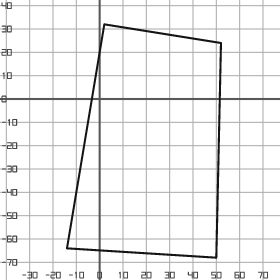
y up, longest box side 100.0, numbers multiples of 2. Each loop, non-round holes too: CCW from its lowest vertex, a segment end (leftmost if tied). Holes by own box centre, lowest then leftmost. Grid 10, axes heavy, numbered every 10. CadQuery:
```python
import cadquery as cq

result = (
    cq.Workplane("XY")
    .moveTo(50.0, -68.0)
    .lineTo(52.0, 24.0)
    .lineTo(2.0, 32.0)
    .lineTo(-14.0, -64.0)
    .close()
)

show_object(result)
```